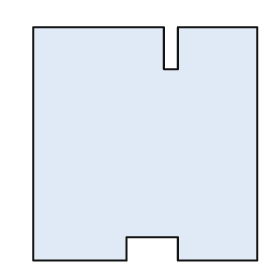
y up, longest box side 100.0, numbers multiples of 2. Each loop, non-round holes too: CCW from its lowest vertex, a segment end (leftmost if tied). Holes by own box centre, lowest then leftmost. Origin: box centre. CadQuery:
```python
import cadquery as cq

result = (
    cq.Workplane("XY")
    .moveTo(-48.0, -50.0)
    .lineTo(-8.0, -50.0)
    .lineTo(-8.0, -40.0)
    .lineTo(14.0, -40.0)
    .lineTo(14.0, -50.0)
    .lineTo(48.0, -50.0)
    .lineTo(48.0, 50.0)
    .lineTo(14.0, 50.0)
    .lineTo(14.0, 32.0)
    .lineTo(8.0, 32.0)
    .lineTo(8.0, 50.0)
    .lineTo(-48.0, 50.0)
    .close()
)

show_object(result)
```